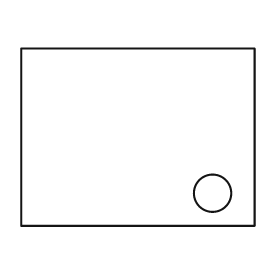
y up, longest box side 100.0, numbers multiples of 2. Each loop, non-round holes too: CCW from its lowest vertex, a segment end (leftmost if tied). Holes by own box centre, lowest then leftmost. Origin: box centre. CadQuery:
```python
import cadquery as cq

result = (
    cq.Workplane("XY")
    .moveTo(-50.0, -38.0)
    .lineTo(50.0, -38.0)
    .lineTo(50.0, 38.0)
    .lineTo(-50.0, 38.0)
    .close()
    .moveTo(32.0, -24.0)
    .circle(8.0)
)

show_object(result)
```